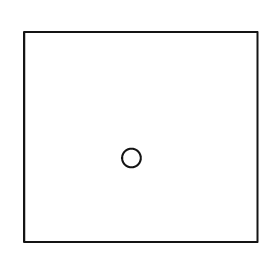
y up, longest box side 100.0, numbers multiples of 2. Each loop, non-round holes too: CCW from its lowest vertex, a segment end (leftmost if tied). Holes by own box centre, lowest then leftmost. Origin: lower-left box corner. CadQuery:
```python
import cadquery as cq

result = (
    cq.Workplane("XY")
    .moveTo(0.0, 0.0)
    .lineTo(100.0, 0.0)
    .lineTo(100.0, 90.0)
    .lineTo(0.0, 90.0)
    .close()
    .moveTo(46.0, 36.0)
    .circle(4.0)
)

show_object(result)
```